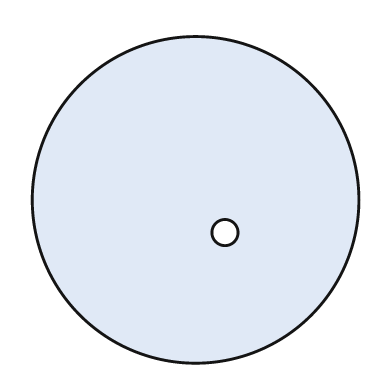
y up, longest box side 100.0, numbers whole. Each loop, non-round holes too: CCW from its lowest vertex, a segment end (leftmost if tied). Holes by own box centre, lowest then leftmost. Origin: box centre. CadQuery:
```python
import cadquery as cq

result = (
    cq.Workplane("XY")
    .moveTo(0.0, 0.0)
    .circle(50.0)
    .moveTo(9.0, -10.0)
    .circle(4.0)
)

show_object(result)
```